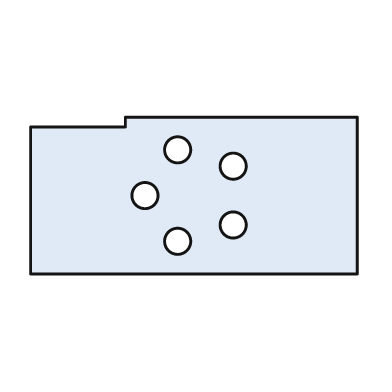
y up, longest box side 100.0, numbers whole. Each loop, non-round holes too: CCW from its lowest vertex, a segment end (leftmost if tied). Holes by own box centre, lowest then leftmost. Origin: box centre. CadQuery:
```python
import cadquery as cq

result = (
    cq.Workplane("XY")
    .moveTo(-50.0, -24.0)
    .lineTo(50.0, -24.0)
    .lineTo(50.0, 24.0)
    .lineTo(-21.0, 24.0)
    .lineTo(-21.0, 21.0)
    .lineTo(-50.0, 21.0)
    .close()
    .moveTo(-5.0, -14.0)
    .circle(4.0)
    .moveTo(12.0, -9.0)
    .circle(4.0)
    .moveTo(-15.0, 0.0)
    .circle(4.0)
    .moveTo(12.0, 9.0)
    .circle(4.0)
    .moveTo(-5.0, 14.0)
    .circle(4.0)
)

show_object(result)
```